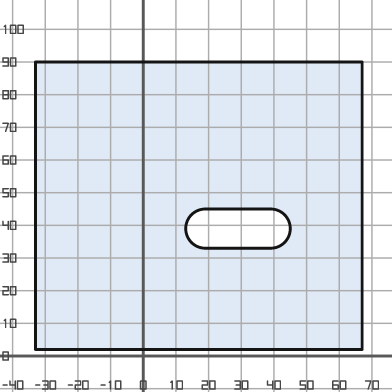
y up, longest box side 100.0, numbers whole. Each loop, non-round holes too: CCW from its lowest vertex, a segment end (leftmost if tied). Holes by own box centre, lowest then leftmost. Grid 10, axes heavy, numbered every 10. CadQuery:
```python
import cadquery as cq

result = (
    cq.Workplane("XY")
    .moveTo(-33.0, 2.0)
    .lineTo(67.0, 2.0)
    .lineTo(67.0, 90.0)
    .lineTo(-33.0, 90.0)
    .close()
    .moveTo(19.0, 33.0)
    .lineTo(39.0, 33.0)
    .threePointArc((45.0, 39.0), (39.0, 45.0))
    .lineTo(19.0, 45.0)
    .threePointArc((13.0, 39.0), (19.0, 33.0))
    .close()
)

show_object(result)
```